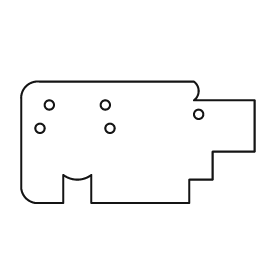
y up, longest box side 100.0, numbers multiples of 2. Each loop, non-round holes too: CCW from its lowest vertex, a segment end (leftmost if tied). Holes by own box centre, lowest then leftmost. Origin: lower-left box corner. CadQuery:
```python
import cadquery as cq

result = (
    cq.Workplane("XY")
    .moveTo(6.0, 0.0)
    .lineTo(18.0, 0.0)
    .lineTo(18.0, 12.0)
    .threePointArc((24.0, 10.0), (30.0, 12.0))
    .lineTo(30.0, 0.0)
    .lineTo(72.0, 0.0)
    .lineTo(72.0, 10.0)
    .lineTo(82.0, 10.0)
    .lineTo(82.0, 22.0)
    .lineTo(100.0, 22.0)
    .lineTo(100.0, 44.0)
    .lineTo(74.0, 44.0)
    .threePointArc((76.0, 48.0), (74.0, 52.0))
    .lineTo(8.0, 52.0)
    .threePointArc((2.0, 50.0), (0.0, 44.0))
    .lineTo(0.0, 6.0)
    .threePointArc((2.0, 2.0), (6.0, 0.0))
    .close()
    .moveTo(8.0, 32.0)
    .circle(2.0)
    .moveTo(38.0, 32.0)
    .circle(2.0)
    .moveTo(76.0, 38.0)
    .circle(2.0)
    .moveTo(12.0, 42.0)
    .circle(2.0)
    .moveTo(36.0, 42.0)
    .circle(2.0)
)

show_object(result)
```